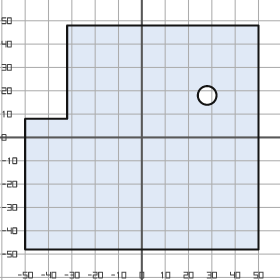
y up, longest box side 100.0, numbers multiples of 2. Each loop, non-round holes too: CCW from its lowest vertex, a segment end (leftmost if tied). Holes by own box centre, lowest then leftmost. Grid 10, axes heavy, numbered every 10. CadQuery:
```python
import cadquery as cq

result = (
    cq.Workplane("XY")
    .moveTo(-50.0, -48.0)
    .lineTo(50.0, -48.0)
    .lineTo(50.0, 48.0)
    .lineTo(-32.0, 48.0)
    .lineTo(-32.0, 8.0)
    .lineTo(-50.0, 8.0)
    .close()
    .moveTo(28.0, 18.0)
    .circle(4.0)
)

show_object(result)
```